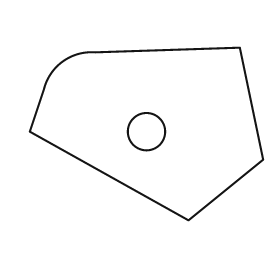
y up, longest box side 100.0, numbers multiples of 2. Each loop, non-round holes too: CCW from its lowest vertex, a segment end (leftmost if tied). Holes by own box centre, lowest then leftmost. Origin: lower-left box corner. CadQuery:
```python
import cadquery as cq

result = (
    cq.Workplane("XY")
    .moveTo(68.0, 0.0)
    .lineTo(100.0, 26.0)
    .lineTo(90.0, 74.0)
    .lineTo(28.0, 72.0)
    .threePointArc((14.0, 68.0), (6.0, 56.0))
    .lineTo(0.0, 38.0)
    .close()
    .moveTo(50.0, 38.0)
    .circle(8.0)
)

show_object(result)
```